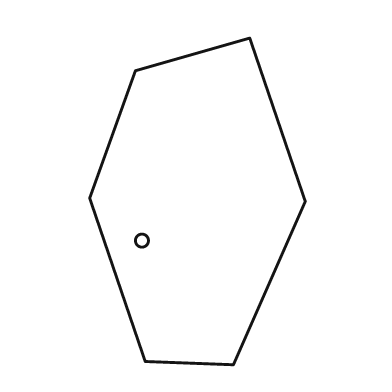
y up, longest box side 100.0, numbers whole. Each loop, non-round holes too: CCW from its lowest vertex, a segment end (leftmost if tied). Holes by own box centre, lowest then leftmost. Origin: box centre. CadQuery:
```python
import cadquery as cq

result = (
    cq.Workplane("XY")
    .moveTo(11.0, -50.0)
    .lineTo(33.0, 0.0)
    .lineTo(16.0, 50.0)
    .lineTo(-19.0, 40.0)
    .lineTo(-33.0, 1.0)
    .lineTo(-16.0, -49.0)
    .close()
    .moveTo(-17.0, -12.0)
    .circle(2.0)
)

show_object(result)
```